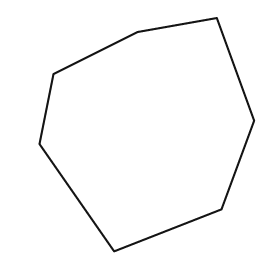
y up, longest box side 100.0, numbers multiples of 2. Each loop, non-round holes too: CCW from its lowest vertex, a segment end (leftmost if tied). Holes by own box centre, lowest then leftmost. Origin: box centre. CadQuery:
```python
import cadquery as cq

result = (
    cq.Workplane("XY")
    .moveTo(-14.0, -50.0)
    .lineTo(32.0, -32.0)
    .lineTo(46.0, 6.0)
    .lineTo(30.0, 50.0)
    .lineTo(-4.0, 44.0)
    .lineTo(-40.0, 26.0)
    .lineTo(-46.0, -4.0)
    .close()
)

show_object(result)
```